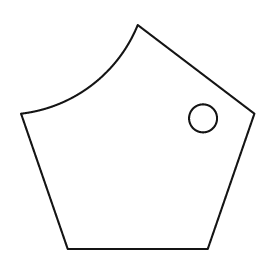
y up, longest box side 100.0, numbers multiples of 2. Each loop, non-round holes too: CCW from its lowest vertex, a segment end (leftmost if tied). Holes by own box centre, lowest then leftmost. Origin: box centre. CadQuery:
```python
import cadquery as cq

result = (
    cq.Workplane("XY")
    .moveTo(-30.0, -48.0)
    .lineTo(30.0, -48.0)
    .lineTo(50.0, 10.0)
    .lineTo(0.0, 48.0)
    .threePointArc((-20.0, 22.0), (-50.0, 10.0))
    .close()
    .moveTo(28.0, 8.0)
    .circle(6.0)
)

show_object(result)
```